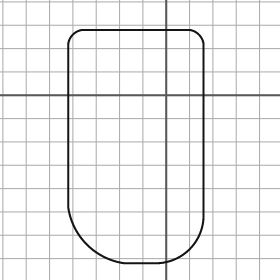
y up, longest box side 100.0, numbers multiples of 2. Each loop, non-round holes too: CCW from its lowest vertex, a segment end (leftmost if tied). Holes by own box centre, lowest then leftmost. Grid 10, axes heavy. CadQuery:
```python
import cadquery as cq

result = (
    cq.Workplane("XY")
    .moveTo(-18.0, -72.0)
    .lineTo(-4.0, -72.0)
    .threePointArc((10.0, -66.0), (16.0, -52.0))
    .lineTo(16.0, 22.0)
    .threePointArc((14.0, 26.0), (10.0, 28.0))
    .lineTo(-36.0, 28.0)
    .threePointArc((-40.0, 26.0), (-42.0, 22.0))
    .lineTo(-42.0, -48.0)
    .threePointArc((-34.0, -64.0), (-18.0, -72.0))
    .close()
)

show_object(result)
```